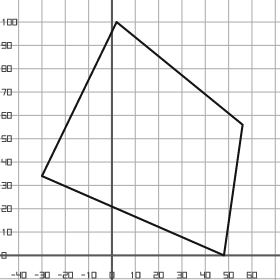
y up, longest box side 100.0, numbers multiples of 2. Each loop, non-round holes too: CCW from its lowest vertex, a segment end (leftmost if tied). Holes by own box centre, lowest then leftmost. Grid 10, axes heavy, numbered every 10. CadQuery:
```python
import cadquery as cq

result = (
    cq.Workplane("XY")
    .moveTo(48.0, 0.0)
    .lineTo(56.0, 56.0)
    .lineTo(2.0, 100.0)
    .lineTo(-30.0, 34.0)
    .close()
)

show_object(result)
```